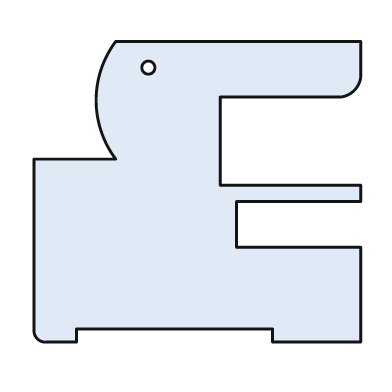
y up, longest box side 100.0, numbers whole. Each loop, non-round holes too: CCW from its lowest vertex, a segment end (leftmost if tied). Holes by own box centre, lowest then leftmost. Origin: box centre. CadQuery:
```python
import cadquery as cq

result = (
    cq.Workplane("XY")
    .moveTo(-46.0, -46.0)
    .lineTo(-37.0, -46.0)
    .lineTo(-37.0, -42.0)
    .lineTo(23.0, -42.0)
    .lineTo(23.0, -46.0)
    .lineTo(50.0, -46.0)
    .lineTo(50.0, -17.0)
    .lineTo(12.0, -17.0)
    .lineTo(12.0, -3.0)
    .lineTo(50.0, -3.0)
    .lineTo(50.0, 2.0)
    .lineTo(7.0, 2.0)
    .lineTo(7.0, 29.0)
    .lineTo(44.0, 29.0)
    .threePointArc((48.0, 31.0), (50.0, 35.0))
    .lineTo(50.0, 46.0)
    .lineTo(-25.0, 46.0)
    .threePointArc((-31.0, 28.0), (-25.0, 10.0))
    .lineTo(-50.0, 10.0)
    .lineTo(-50.0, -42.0)
    .threePointArc((-49.0, -45.0), (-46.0, -46.0))
    .close()
    .moveTo(-15.0, 38.0)
    .circle(2.0)
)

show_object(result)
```